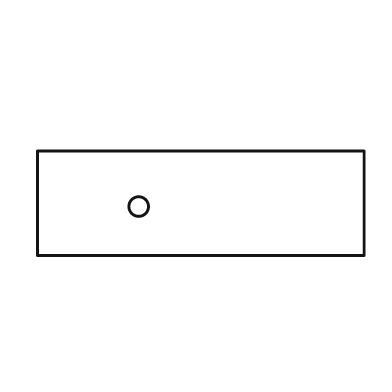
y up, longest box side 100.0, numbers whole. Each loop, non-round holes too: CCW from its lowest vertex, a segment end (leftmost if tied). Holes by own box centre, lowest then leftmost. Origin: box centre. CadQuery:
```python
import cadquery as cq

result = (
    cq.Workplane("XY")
    .moveTo(-50.0, -16.0)
    .lineTo(50.0, -16.0)
    .lineTo(50.0, 16.0)
    .lineTo(-50.0, 16.0)
    .close()
    .moveTo(-19.0, -1.0)
    .circle(3.0)
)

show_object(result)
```